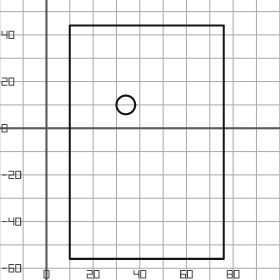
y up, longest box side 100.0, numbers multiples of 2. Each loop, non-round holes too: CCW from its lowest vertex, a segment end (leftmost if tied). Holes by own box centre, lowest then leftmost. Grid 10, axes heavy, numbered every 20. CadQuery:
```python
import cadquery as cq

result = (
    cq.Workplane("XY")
    .moveTo(10.0, -56.0)
    .lineTo(76.0, -56.0)
    .lineTo(76.0, 44.0)
    .lineTo(10.0, 44.0)
    .close()
    .moveTo(34.0, 10.0)
    .circle(4.0)
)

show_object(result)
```